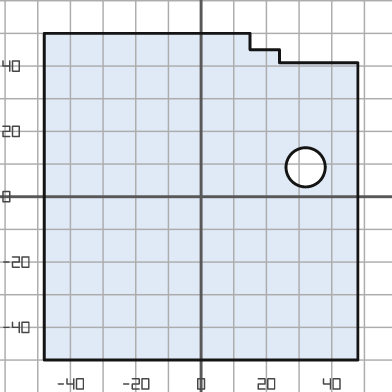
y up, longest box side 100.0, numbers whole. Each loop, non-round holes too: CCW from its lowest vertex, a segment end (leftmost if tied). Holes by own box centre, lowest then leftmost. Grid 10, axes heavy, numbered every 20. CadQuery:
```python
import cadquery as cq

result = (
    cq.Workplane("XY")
    .moveTo(-48.0, -50.0)
    .lineTo(48.0, -50.0)
    .lineTo(48.0, 41.0)
    .lineTo(24.0, 41.0)
    .lineTo(24.0, 45.0)
    .lineTo(15.0, 45.0)
    .lineTo(15.0, 50.0)
    .lineTo(-48.0, 50.0)
    .close()
    .moveTo(32.0, 9.0)
    .circle(6.0)
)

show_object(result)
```